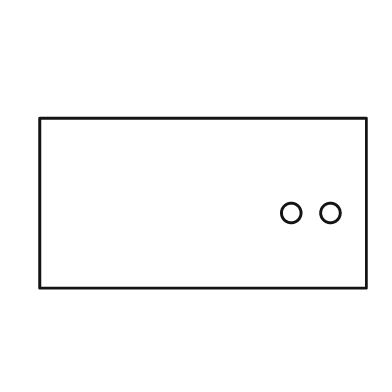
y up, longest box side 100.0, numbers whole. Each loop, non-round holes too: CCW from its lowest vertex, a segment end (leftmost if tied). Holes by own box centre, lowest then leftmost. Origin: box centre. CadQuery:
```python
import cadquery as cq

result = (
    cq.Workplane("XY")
    .moveTo(-50.0, -26.0)
    .lineTo(50.0, -26.0)
    .lineTo(50.0, 26.0)
    .lineTo(-50.0, 26.0)
    .close()
    .moveTo(27.0, -3.0)
    .circle(3.0)
    .moveTo(39.0, -3.0)
    .circle(3.0)
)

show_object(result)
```